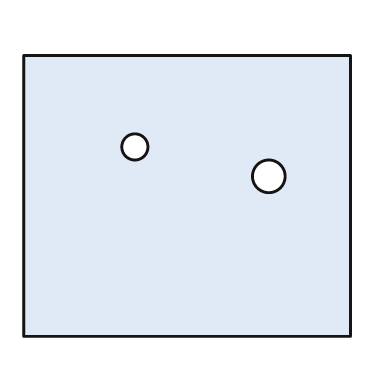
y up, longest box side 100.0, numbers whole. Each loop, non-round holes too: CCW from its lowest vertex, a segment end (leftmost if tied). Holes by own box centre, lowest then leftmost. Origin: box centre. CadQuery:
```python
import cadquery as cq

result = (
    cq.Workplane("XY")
    .moveTo(-50.0, -43.0)
    .lineTo(50.0, -43.0)
    .lineTo(50.0, 43.0)
    .lineTo(-50.0, 43.0)
    .close()
    .moveTo(25.0, 6.0)
    .circle(5.0)
    .moveTo(-16.0, 15.0)
    .circle(4.0)
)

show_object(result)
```